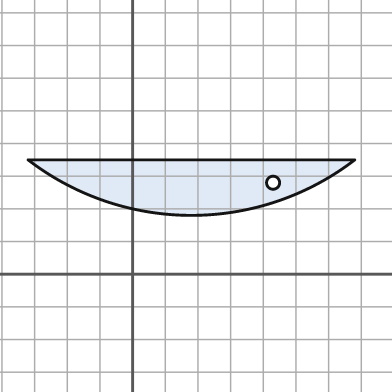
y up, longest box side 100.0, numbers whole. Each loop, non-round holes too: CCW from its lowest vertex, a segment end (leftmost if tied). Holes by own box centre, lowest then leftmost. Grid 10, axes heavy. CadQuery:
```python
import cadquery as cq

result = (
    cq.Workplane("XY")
    .moveTo(-32.0, 35.0)
    .threePointArc((18.0, 18.0), (68.0, 35.0))
    .close()
    .moveTo(43.0, 28.0)
    .circle(2.0)
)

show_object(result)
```